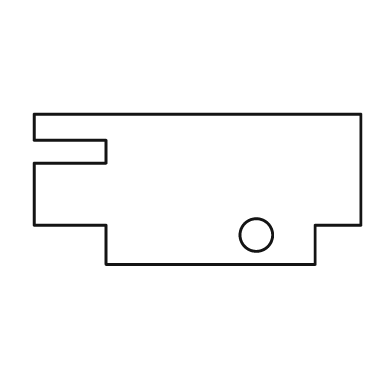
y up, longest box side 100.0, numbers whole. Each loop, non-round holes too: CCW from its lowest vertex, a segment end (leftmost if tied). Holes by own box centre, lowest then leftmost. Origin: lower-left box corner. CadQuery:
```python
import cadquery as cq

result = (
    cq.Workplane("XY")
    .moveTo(22.0, 0.0)
    .lineTo(86.0, 0.0)
    .lineTo(86.0, 12.0)
    .lineTo(100.0, 12.0)
    .lineTo(100.0, 46.0)
    .lineTo(0.0, 46.0)
    .lineTo(0.0, 38.0)
    .lineTo(22.0, 38.0)
    .lineTo(22.0, 31.0)
    .lineTo(0.0, 31.0)
    .lineTo(0.0, 12.0)
    .lineTo(22.0, 12.0)
    .close()
    .moveTo(68.0, 9.0)
    .circle(5.0)
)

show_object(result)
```